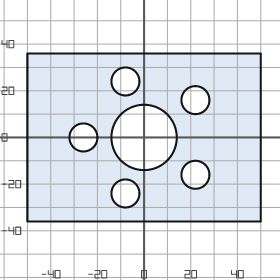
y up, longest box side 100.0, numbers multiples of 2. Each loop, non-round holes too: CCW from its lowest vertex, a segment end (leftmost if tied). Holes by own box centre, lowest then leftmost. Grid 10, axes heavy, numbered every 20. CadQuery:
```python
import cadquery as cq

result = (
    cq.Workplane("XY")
    .moveTo(-50.0, -36.0)
    .lineTo(50.0, -36.0)
    .lineTo(50.0, 36.0)
    .lineTo(-50.0, 36.0)
    .close()
    .moveTo(-8.0, -24.0)
    .circle(6.0)
    .moveTo(22.0, -16.0)
    .circle(6.0)
    .moveTo(-26.0, 0.0)
    .circle(6.0)
    .moveTo(0.0, 0.0)
    .circle(14.0)
    .moveTo(22.0, 16.0)
    .circle(6.0)
    .moveTo(-8.0, 24.0)
    .circle(6.0)
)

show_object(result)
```